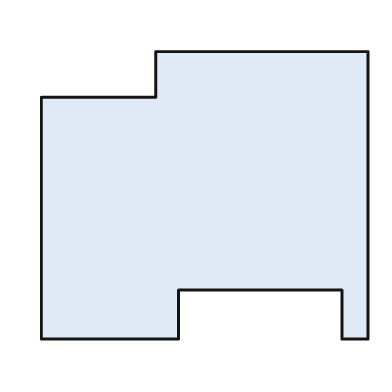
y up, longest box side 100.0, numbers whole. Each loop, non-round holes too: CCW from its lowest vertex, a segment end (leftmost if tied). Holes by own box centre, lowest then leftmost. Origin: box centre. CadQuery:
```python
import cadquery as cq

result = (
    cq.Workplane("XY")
    .moveTo(-50.0, -44.0)
    .lineTo(-8.0, -44.0)
    .lineTo(-8.0, -29.0)
    .lineTo(42.0, -29.0)
    .lineTo(42.0, -44.0)
    .lineTo(50.0, -44.0)
    .lineTo(50.0, 44.0)
    .lineTo(-15.0, 44.0)
    .lineTo(-15.0, 30.0)
    .lineTo(-50.0, 30.0)
    .close()
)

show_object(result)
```